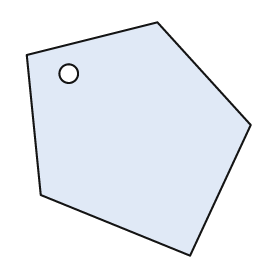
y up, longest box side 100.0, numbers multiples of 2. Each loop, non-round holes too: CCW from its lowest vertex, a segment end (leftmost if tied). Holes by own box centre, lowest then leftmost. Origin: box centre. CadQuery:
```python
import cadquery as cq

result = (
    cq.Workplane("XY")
    .moveTo(22.0, -50.0)
    .lineTo(48.0, 6.0)
    .lineTo(8.0, 50.0)
    .lineTo(-48.0, 36.0)
    .lineTo(-42.0, -24.0)
    .close()
    .moveTo(-30.0, 28.0)
    .circle(4.0)
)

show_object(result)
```